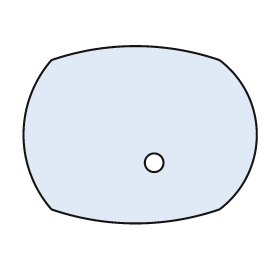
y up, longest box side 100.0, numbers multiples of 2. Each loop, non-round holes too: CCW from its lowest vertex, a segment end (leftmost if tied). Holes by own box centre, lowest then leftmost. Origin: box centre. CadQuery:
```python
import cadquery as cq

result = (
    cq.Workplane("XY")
    .moveTo(-38.0, -32.0)
    .threePointArc((-2.0, -38.0), (34.0, -32.0))
    .threePointArc((50.0, 0.0), (34.0, 32.0))
    .threePointArc((-2.0, 38.0), (-38.0, 32.0))
    .threePointArc((-50.0, 0.0), (-38.0, -32.0))
    .close()
    .moveTo(6.0, -12.0)
    .circle(4.0)
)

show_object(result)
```